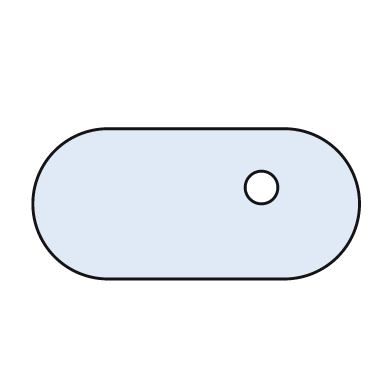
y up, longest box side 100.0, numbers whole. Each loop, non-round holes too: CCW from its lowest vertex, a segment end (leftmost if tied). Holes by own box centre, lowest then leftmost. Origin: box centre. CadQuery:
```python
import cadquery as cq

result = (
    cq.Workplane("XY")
    .moveTo(-27.0, -23.0)
    .lineTo(27.0, -23.0)
    .threePointArc((50.0, 0.0), (27.0, 23.0))
    .lineTo(-27.0, 23.0)
    .threePointArc((-50.0, 0.0), (-27.0, -23.0))
    .close()
    .moveTo(20.0, 5.0)
    .circle(5.0)
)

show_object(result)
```